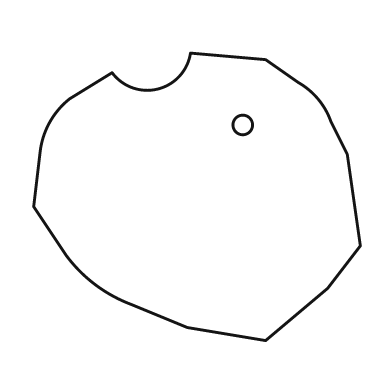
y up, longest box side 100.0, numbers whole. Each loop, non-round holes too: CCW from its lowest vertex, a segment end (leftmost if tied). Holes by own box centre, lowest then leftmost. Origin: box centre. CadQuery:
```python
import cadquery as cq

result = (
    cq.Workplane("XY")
    .moveTo(21.0, -44.0)
    .lineTo(40.0, -28.0)
    .lineTo(50.0, -15.0)
    .lineTo(46.0, 13.0)
    .lineTo(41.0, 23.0)
    .threePointArc((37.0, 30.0), (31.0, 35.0))
    .lineTo(21.0, 42.0)
    .lineTo(-2.0, 44.0)
    .threePointArc((-12.0, 33.0), (-26.0, 38.0))
    .lineTo(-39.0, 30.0)
    .threePointArc((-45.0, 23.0), (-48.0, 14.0))
    .lineTo(-50.0, -3.0)
    .lineTo(-40.0, -18.0)
    .threePointArc((-31.0, -27.0), (-20.0, -33.0))
    .lineTo(-3.0, -40.0)
    .close()
    .moveTo(14.0, 22.0)
    .circle(3.0)
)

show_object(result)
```